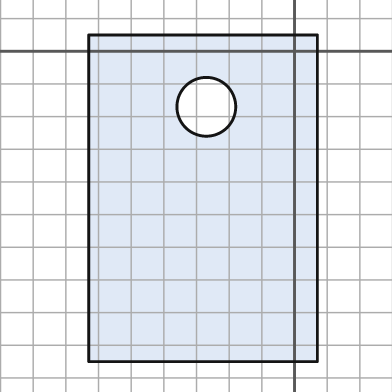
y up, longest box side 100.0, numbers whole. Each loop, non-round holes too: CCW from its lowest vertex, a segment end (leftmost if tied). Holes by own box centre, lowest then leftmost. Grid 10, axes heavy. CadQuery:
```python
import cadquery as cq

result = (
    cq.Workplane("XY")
    .moveTo(-63.0, -95.0)
    .lineTo(7.0, -95.0)
    .lineTo(7.0, 5.0)
    .lineTo(-63.0, 5.0)
    .close()
    .moveTo(-27.0, -17.0)
    .circle(9.0)
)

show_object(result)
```